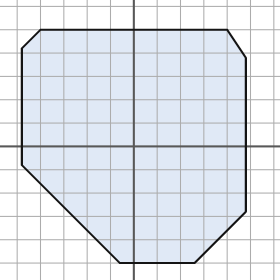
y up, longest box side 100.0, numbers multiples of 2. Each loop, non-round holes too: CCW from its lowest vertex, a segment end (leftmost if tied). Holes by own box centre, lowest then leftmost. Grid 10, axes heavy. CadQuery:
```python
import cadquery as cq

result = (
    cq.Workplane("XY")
    .moveTo(-6.0, -50.0)
    .lineTo(26.0, -50.0)
    .lineTo(48.0, -28.0)
    .lineTo(48.0, 38.0)
    .lineTo(40.0, 50.0)
    .lineTo(-40.0, 50.0)
    .lineTo(-48.0, 42.0)
    .lineTo(-48.0, -8.0)
    .close()
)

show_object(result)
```